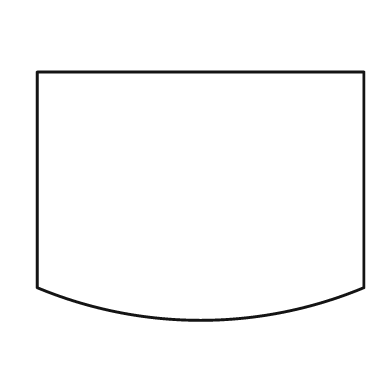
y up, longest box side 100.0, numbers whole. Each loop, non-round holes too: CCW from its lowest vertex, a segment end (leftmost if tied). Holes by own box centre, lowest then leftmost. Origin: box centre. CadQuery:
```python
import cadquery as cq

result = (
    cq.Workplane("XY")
    .moveTo(-50.0, -28.0)
    .threePointArc((0.0, -38.0), (50.0, -28.0))
    .lineTo(50.0, 38.0)
    .lineTo(-50.0, 38.0)
    .close()
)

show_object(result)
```